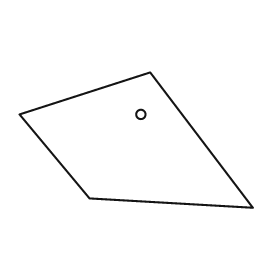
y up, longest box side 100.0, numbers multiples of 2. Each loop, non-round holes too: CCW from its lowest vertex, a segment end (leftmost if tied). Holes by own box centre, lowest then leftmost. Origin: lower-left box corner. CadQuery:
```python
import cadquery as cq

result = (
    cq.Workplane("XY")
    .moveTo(100.0, 0.0)
    .lineTo(56.0, 58.0)
    .lineTo(0.0, 40.0)
    .lineTo(30.0, 4.0)
    .close()
    .moveTo(52.0, 40.0)
    .circle(2.0)
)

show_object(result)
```